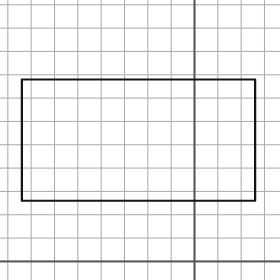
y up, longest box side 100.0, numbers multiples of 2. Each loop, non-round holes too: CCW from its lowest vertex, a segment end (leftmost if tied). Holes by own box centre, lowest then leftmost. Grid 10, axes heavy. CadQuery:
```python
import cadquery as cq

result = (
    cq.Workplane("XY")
    .moveTo(-74.0, 26.0)
    .lineTo(26.0, 26.0)
    .lineTo(26.0, 78.0)
    .lineTo(-74.0, 78.0)
    .close()
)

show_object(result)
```